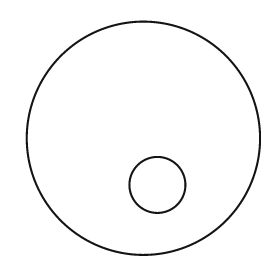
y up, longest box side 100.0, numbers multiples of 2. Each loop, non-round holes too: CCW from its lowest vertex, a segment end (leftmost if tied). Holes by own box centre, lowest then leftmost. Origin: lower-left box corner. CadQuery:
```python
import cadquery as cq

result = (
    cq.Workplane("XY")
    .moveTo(50.0, 50.0)
    .circle(50.0)
    .moveTo(56.0, 30.0)
    .circle(12.0)
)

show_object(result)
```